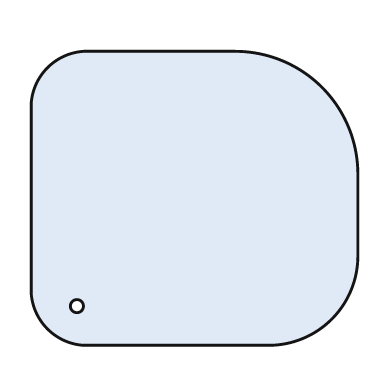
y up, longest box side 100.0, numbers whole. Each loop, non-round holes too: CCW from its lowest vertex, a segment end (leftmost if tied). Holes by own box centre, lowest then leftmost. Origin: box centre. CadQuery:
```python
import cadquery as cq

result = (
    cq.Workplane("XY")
    .moveTo(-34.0, -45.0)
    .lineTo(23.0, -45.0)
    .threePointArc((42.0, -37.0), (50.0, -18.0))
    .lineTo(50.0, 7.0)
    .threePointArc((39.0, 34.0), (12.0, 45.0))
    .lineTo(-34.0, 45.0)
    .threePointArc((-45.0, 40.0), (-50.0, 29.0))
    .lineTo(-50.0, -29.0)
    .threePointArc((-45.0, -40.0), (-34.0, -45.0))
    .close()
    .moveTo(-36.0, -33.0)
    .circle(2.0)
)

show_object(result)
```